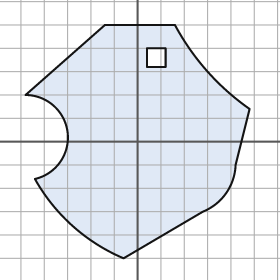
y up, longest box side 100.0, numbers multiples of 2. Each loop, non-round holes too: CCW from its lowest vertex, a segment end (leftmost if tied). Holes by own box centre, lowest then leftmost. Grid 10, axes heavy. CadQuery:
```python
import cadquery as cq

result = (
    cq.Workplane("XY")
    .moveTo(-6.0, -50.0)
    .lineTo(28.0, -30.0)
    .threePointArc((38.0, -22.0), (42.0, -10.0))
    .lineTo(48.0, 14.0)
    .threePointArc((30.0, 30.0), (16.0, 50.0))
    .lineTo(-14.0, 50.0)
    .lineTo(-48.0, 20.0)
    .threePointArc((-30.0, 4.0), (-44.0, -16.0))
    .threePointArc((-28.0, -36.0), (-6.0, -50.0))
    .close()
    .moveTo(4.0, 32.0)
    .lineTo(12.0, 32.0)
    .lineTo(12.0, 40.0)
    .lineTo(4.0, 40.0)
    .close()
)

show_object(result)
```